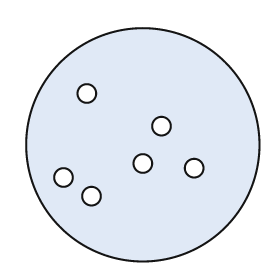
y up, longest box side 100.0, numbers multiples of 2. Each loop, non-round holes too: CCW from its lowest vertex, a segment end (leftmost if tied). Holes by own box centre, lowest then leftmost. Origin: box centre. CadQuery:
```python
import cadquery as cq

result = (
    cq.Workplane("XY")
    .moveTo(0.0, 0.0)
    .circle(50.0)
    .moveTo(-22.0, -22.0)
    .circle(4.0)
    .moveTo(-34.0, -14.0)
    .circle(4.0)
    .moveTo(22.0, -10.0)
    .circle(4.0)
    .moveTo(0.0, -8.0)
    .circle(4.0)
    .moveTo(8.0, 8.0)
    .circle(4.0)
    .moveTo(-24.0, 22.0)
    .circle(4.0)
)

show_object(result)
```